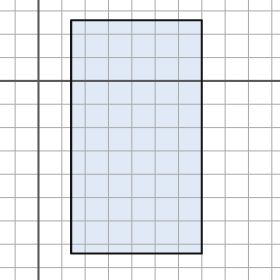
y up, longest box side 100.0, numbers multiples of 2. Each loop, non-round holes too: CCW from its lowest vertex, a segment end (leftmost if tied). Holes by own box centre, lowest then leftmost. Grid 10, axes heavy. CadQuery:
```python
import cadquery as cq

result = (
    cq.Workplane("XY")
    .moveTo(14.0, -74.0)
    .lineTo(70.0, -74.0)
    .lineTo(70.0, 26.0)
    .lineTo(14.0, 26.0)
    .close()
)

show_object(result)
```